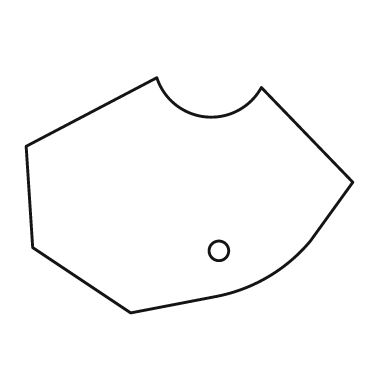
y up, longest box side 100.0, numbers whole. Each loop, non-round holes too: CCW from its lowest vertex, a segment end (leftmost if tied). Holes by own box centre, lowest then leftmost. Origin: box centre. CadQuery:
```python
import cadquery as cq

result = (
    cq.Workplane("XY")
    .moveTo(-18.0, -36.0)
    .lineTo(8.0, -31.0)
    .threePointArc((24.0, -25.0), (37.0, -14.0))
    .lineTo(50.0, 4.0)
    .lineTo(22.0, 33.0)
    .threePointArc((5.0, 24.0), (-10.0, 36.0))
    .lineTo(-50.0, 15.0)
    .lineTo(-48.0, -16.0)
    .close()
    .moveTo(9.0, -17.0)
    .circle(3.0)
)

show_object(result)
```